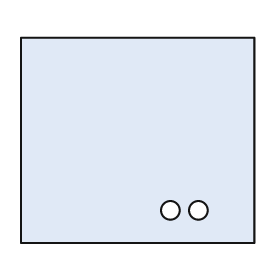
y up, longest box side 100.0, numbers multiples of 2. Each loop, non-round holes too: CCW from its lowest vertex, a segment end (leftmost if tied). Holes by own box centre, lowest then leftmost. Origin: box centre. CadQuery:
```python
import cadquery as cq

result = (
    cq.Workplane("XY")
    .moveTo(-50.0, -44.0)
    .lineTo(50.0, -44.0)
    .lineTo(50.0, 44.0)
    .lineTo(-50.0, 44.0)
    .close()
    .moveTo(14.0, -30.0)
    .circle(4.0)
    .moveTo(26.0, -30.0)
    .circle(4.0)
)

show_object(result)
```